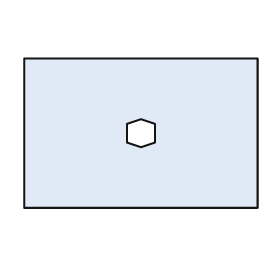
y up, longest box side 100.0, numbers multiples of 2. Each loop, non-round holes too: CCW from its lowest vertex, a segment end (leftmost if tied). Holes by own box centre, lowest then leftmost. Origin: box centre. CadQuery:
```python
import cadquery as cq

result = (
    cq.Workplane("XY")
    .moveTo(-50.0, -32.0)
    .lineTo(50.0, -32.0)
    .lineTo(50.0, 32.0)
    .lineTo(-50.0, 32.0)
    .close()
    .moveTo(0.0, -6.0)
    .lineTo(6.0, -4.0)
    .lineTo(6.0, 4.0)
    .lineTo(0.0, 6.0)
    .lineTo(-6.0, 4.0)
    .lineTo(-6.0, -4.0)
    .close()
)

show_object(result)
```